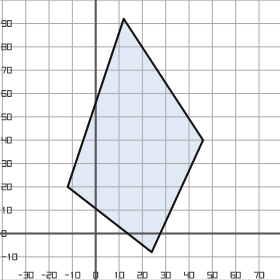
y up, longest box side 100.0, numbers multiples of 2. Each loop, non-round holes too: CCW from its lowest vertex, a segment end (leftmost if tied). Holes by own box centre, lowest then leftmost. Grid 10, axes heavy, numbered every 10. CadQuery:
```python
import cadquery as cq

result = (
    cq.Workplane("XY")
    .moveTo(24.0, -8.0)
    .lineTo(46.0, 40.0)
    .lineTo(12.0, 92.0)
    .lineTo(-12.0, 20.0)
    .close()
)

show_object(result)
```